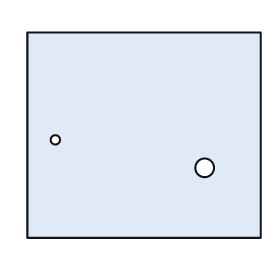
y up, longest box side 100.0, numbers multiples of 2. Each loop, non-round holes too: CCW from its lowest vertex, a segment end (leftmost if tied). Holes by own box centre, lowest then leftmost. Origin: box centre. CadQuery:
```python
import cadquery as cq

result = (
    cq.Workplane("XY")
    .moveTo(-50.0, -44.0)
    .lineTo(50.0, -44.0)
    .lineTo(50.0, 44.0)
    .lineTo(-50.0, 44.0)
    .close()
    .moveTo(26.0, -14.0)
    .circle(4.0)
    .moveTo(-38.0, -2.0)
    .circle(2.0)
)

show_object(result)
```